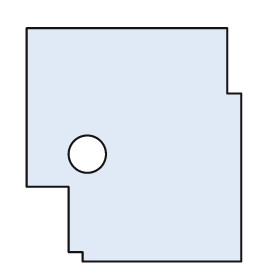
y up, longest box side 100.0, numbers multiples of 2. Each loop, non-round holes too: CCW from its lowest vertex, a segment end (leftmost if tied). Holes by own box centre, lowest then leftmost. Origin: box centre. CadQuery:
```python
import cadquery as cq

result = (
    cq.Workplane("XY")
    .moveTo(-22.0, -50.0)
    .lineTo(46.0, -50.0)
    .lineTo(46.0, 22.0)
    .lineTo(40.0, 22.0)
    .lineTo(40.0, 50.0)
    .lineTo(-46.0, 50.0)
    .lineTo(-46.0, -18.0)
    .lineTo(-28.0, -18.0)
    .lineTo(-28.0, -46.0)
    .lineTo(-22.0, -46.0)
    .close()
    .moveTo(-20.0, -4.0)
    .circle(8.0)
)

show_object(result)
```